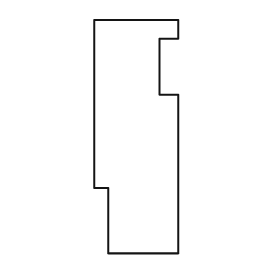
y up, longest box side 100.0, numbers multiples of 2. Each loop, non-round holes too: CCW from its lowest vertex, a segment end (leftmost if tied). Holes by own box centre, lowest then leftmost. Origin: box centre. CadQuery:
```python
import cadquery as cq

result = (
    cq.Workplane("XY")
    .moveTo(-12.0, -50.0)
    .lineTo(18.0, -50.0)
    .lineTo(18.0, 18.0)
    .lineTo(10.0, 18.0)
    .lineTo(10.0, 42.0)
    .lineTo(18.0, 42.0)
    .lineTo(18.0, 50.0)
    .lineTo(-18.0, 50.0)
    .lineTo(-18.0, -22.0)
    .lineTo(-12.0, -22.0)
    .close()
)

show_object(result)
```